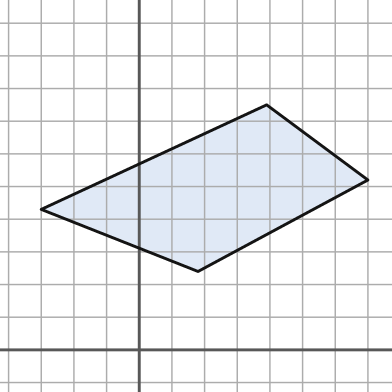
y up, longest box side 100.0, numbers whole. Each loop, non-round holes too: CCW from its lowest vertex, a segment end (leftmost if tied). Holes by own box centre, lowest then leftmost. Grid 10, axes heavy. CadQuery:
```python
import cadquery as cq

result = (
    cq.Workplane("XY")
    .moveTo(18.0, 24.0)
    .lineTo(70.0, 52.0)
    .lineTo(39.0, 75.0)
    .lineTo(-30.0, 43.0)
    .close()
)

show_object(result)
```